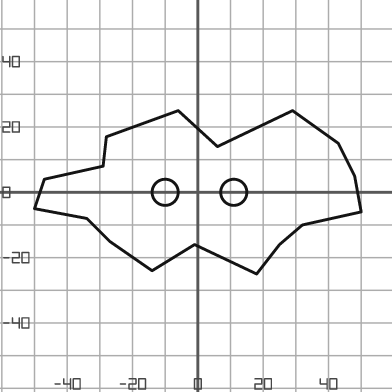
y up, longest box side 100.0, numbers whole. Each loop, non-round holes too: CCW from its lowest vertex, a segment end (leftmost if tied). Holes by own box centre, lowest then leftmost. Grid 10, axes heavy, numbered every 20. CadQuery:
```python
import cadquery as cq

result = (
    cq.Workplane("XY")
    .moveTo(18.0, -25.0)
    .lineTo(25.0, -16.0)
    .lineTo(32.0, -10.0)
    .lineTo(50.0, -6.0)
    .lineTo(48.0, 5.0)
    .lineTo(43.0, 15.0)
    .lineTo(29.0, 25.0)
    .lineTo(6.0, 14.0)
    .lineTo(-6.0, 25.0)
    .lineTo(-28.0, 17.0)
    .lineTo(-29.0, 8.0)
    .lineTo(-47.0, 4.0)
    .lineTo(-50.0, -5.0)
    .lineTo(-34.0, -8.0)
    .lineTo(-27.0, -15.0)
    .lineTo(-14.0, -24.0)
    .lineTo(-1.0, -16.0)
    .close()
    .moveTo(-10.0, 0.0)
    .circle(4.0)
    .moveTo(11.0, 0.0)
    .circle(4.0)
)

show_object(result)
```